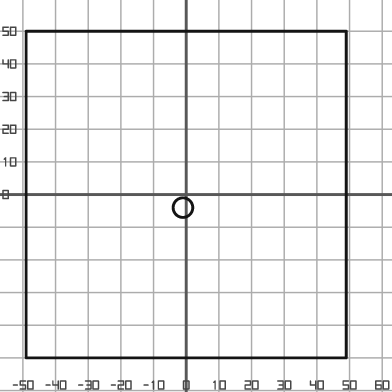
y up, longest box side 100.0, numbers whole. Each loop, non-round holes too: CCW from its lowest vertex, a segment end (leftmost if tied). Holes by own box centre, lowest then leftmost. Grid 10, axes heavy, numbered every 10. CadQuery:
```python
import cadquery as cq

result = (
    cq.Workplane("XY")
    .moveTo(-49.0, -50.0)
    .lineTo(49.0, -50.0)
    .lineTo(49.0, 50.0)
    .lineTo(-49.0, 50.0)
    .close()
    .moveTo(-1.0, -4.0)
    .circle(3.0)
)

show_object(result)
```